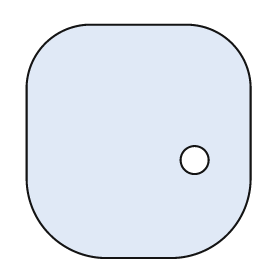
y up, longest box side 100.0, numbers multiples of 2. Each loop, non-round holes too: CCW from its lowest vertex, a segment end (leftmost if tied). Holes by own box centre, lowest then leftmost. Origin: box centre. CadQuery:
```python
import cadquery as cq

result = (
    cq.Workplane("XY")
    .moveTo(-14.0, -50.0)
    .lineTo(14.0, -50.0)
    .threePointArc((38.0, -40.0), (48.0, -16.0))
    .lineTo(48.0, 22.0)
    .threePointArc((40.0, 42.0), (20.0, 50.0))
    .lineTo(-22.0, 50.0)
    .threePointArc((-40.0, 42.0), (-48.0, 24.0))
    .lineTo(-48.0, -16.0)
    .threePointArc((-38.0, -40.0), (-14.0, -50.0))
    .close()
    .moveTo(24.0, -8.0)
    .circle(6.0)
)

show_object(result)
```